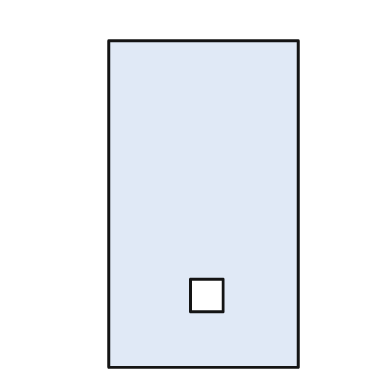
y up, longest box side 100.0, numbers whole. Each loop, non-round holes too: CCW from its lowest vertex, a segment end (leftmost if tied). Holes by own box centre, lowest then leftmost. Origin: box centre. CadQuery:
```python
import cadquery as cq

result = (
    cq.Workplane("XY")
    .moveTo(-29.0, -50.0)
    .lineTo(29.0, -50.0)
    .lineTo(29.0, 50.0)
    .lineTo(-29.0, 50.0)
    .close()
    .moveTo(-4.0, -33.0)
    .lineTo(6.0, -33.0)
    .lineTo(6.0, -23.0)
    .lineTo(-4.0, -23.0)
    .close()
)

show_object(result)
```